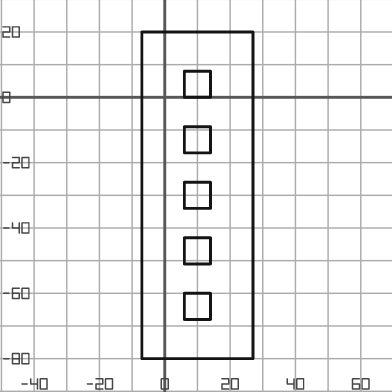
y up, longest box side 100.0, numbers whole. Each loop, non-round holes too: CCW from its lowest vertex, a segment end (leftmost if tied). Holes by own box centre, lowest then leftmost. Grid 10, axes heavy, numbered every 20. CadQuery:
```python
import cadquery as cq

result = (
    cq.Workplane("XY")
    .moveTo(-7.0, -80.0)
    .lineTo(27.0, -80.0)
    .lineTo(27.0, 20.0)
    .lineTo(-7.0, 20.0)
    .close()
    .moveTo(6.0, -68.0)
    .lineTo(14.0, -68.0)
    .lineTo(14.0, -60.0)
    .lineTo(6.0, -60.0)
    .close()
    .moveTo(6.0, -51.0)
    .lineTo(14.0, -51.0)
    .lineTo(14.0, -43.0)
    .lineTo(6.0, -43.0)
    .close()
    .moveTo(6.0, -34.0)
    .lineTo(14.0, -34.0)
    .lineTo(14.0, -26.0)
    .lineTo(6.0, -26.0)
    .close()
    .moveTo(6.0, -17.0)
    .lineTo(14.0, -17.0)
    .lineTo(14.0, -9.0)
    .lineTo(6.0, -9.0)
    .close()
    .moveTo(6.0, 0.0)
    .lineTo(14.0, 0.0)
    .lineTo(14.0, 8.0)
    .lineTo(6.0, 8.0)
    .close()
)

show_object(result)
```